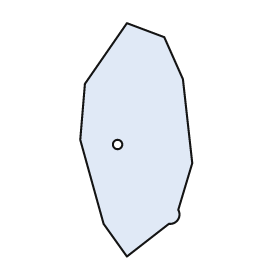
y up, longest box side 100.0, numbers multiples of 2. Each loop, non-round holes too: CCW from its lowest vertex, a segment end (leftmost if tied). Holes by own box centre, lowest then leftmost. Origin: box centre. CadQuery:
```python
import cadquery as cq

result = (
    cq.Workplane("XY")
    .moveTo(-4.0, -50.0)
    .lineTo(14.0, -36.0)
    .threePointArc((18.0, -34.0), (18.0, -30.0))
    .lineTo(24.0, -10.0)
    .lineTo(20.0, 26.0)
    .lineTo(12.0, 44.0)
    .lineTo(-4.0, 50.0)
    .lineTo(-22.0, 24.0)
    .lineTo(-24.0, 0.0)
    .lineTo(-14.0, -36.0)
    .close()
    .moveTo(-8.0, -2.0)
    .circle(2.0)
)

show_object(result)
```